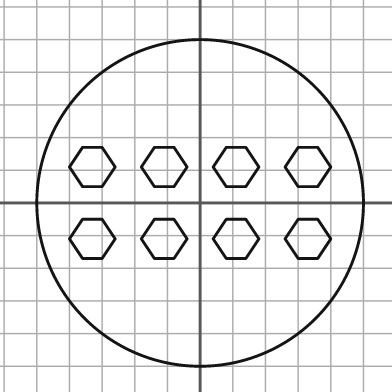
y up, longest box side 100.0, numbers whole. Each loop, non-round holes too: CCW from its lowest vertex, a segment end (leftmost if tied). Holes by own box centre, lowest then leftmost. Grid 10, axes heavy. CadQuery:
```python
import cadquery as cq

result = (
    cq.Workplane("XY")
    .moveTo(0.0, 0.0)
    .circle(50.0)
    .moveTo(-36.0, -17.0)
    .lineTo(-30.0, -17.0)
    .lineTo(-26.0, -11.0)
    .lineTo(-30.0, -5.0)
    .lineTo(-36.0, -5.0)
    .lineTo(-40.0, -11.0)
    .close()
    .moveTo(-14.0, -17.0)
    .lineTo(-8.0, -17.0)
    .lineTo(-4.0, -11.0)
    .lineTo(-8.0, -5.0)
    .lineTo(-14.0, -5.0)
    .lineTo(-18.0, -11.0)
    .close()
    .moveTo(8.0, -17.0)
    .lineTo(14.0, -17.0)
    .lineTo(18.0, -11.0)
    .lineTo(14.0, -5.0)
    .lineTo(8.0, -5.0)
    .lineTo(4.0, -11.0)
    .close()
    .moveTo(30.0, -17.0)
    .lineTo(36.0, -17.0)
    .lineTo(40.0, -11.0)
    .lineTo(36.0, -5.0)
    .lineTo(30.0, -5.0)
    .lineTo(26.0, -11.0)
    .close()
    .moveTo(-36.0, 5.0)
    .lineTo(-30.0, 5.0)
    .lineTo(-26.0, 11.0)
    .lineTo(-30.0, 17.0)
    .lineTo(-36.0, 17.0)
    .lineTo(-40.0, 11.0)
    .close()
    .moveTo(-14.0, 5.0)
    .lineTo(-8.0, 5.0)
    .lineTo(-4.0, 11.0)
    .lineTo(-8.0, 17.0)
    .lineTo(-14.0, 17.0)
    .lineTo(-18.0, 11.0)
    .close()
    .moveTo(8.0, 5.0)
    .lineTo(14.0, 5.0)
    .lineTo(18.0, 11.0)
    .lineTo(14.0, 17.0)
    .lineTo(8.0, 17.0)
    .lineTo(4.0, 11.0)
    .close()
    .moveTo(30.0, 5.0)
    .lineTo(36.0, 5.0)
    .lineTo(40.0, 11.0)
    .lineTo(36.0, 17.0)
    .lineTo(30.0, 17.0)
    .lineTo(26.0, 11.0)
    .close()
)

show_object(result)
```